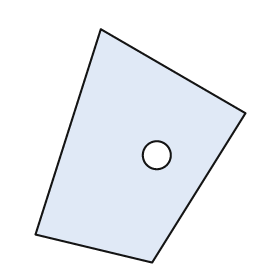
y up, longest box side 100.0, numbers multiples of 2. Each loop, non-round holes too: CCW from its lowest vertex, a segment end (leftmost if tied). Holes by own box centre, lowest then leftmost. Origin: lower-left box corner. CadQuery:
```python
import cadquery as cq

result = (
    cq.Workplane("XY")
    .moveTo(50.0, 0.0)
    .lineTo(90.0, 64.0)
    .lineTo(28.0, 100.0)
    .lineTo(0.0, 12.0)
    .close()
    .moveTo(52.0, 46.0)
    .circle(6.0)
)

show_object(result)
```